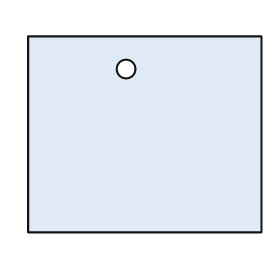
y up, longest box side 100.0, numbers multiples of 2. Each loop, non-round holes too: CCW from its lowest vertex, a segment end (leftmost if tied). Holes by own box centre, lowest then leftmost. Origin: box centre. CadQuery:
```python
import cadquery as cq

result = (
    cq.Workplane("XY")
    .moveTo(-50.0, -42.0)
    .lineTo(50.0, -42.0)
    .lineTo(50.0, 42.0)
    .lineTo(-50.0, 42.0)
    .close()
    .moveTo(-8.0, 28.0)
    .circle(4.0)
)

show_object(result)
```